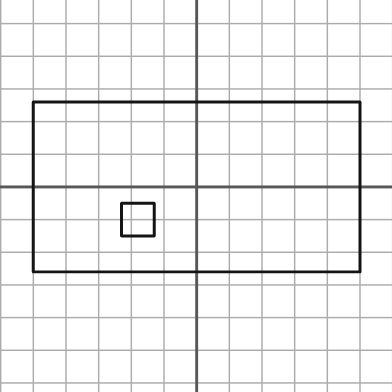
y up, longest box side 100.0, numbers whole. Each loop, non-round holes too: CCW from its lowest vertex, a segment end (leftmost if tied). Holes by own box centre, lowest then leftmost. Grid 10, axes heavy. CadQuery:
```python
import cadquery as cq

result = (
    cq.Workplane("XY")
    .moveTo(-50.0, -26.0)
    .lineTo(50.0, -26.0)
    .lineTo(50.0, 26.0)
    .lineTo(-50.0, 26.0)
    .close()
    .moveTo(-23.0, -15.0)
    .lineTo(-13.0, -15.0)
    .lineTo(-13.0, -5.0)
    .lineTo(-23.0, -5.0)
    .close()
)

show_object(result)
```